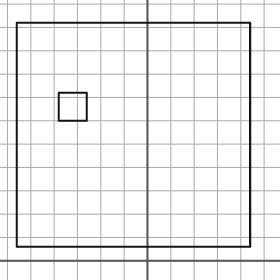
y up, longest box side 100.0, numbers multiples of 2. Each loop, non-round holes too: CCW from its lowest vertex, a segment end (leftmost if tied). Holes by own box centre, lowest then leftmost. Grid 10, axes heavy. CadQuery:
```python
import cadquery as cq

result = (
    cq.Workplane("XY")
    .moveTo(-56.0, 6.0)
    .lineTo(44.0, 6.0)
    .lineTo(44.0, 102.0)
    .lineTo(-56.0, 102.0)
    .close()
    .moveTo(-38.0, 60.0)
    .lineTo(-26.0, 60.0)
    .lineTo(-26.0, 72.0)
    .lineTo(-38.0, 72.0)
    .close()
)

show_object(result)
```